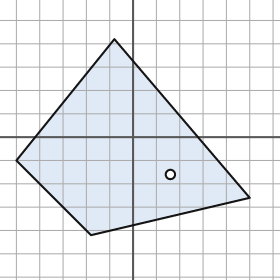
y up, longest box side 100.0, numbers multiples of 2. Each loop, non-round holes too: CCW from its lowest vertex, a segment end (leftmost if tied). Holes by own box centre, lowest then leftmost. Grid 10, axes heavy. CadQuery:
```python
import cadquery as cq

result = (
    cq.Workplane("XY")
    .moveTo(-18.0, -42.0)
    .lineTo(50.0, -26.0)
    .lineTo(-8.0, 42.0)
    .lineTo(-50.0, -10.0)
    .close()
    .moveTo(16.0, -16.0)
    .circle(2.0)
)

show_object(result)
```